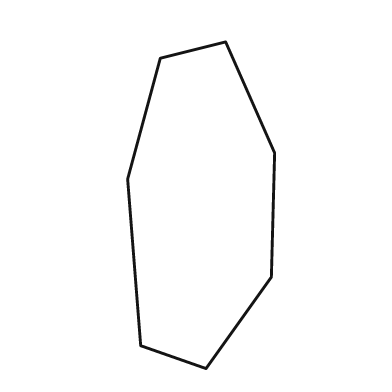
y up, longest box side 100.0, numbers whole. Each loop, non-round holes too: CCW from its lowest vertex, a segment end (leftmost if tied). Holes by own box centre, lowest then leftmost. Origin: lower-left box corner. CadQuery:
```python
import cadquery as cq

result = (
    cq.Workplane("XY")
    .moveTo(24.0, 0.0)
    .lineTo(44.0, 28.0)
    .lineTo(45.0, 66.0)
    .lineTo(30.0, 100.0)
    .lineTo(10.0, 95.0)
    .lineTo(0.0, 58.0)
    .lineTo(4.0, 7.0)
    .close()
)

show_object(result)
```